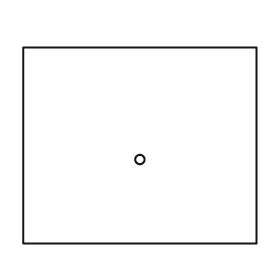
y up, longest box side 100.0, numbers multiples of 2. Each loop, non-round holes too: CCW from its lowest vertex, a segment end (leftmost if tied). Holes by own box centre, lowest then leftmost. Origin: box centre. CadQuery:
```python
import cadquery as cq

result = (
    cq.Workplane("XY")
    .moveTo(-50.0, -42.0)
    .lineTo(50.0, -42.0)
    .lineTo(50.0, 42.0)
    .lineTo(-50.0, 42.0)
    .close()
    .moveTo(0.0, -6.0)
    .circle(2.0)
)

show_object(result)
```